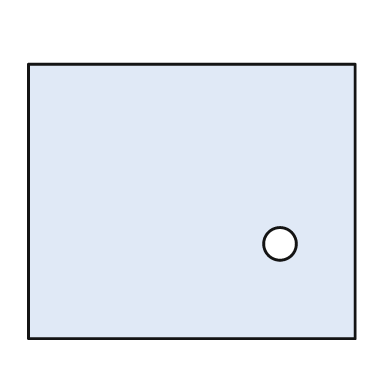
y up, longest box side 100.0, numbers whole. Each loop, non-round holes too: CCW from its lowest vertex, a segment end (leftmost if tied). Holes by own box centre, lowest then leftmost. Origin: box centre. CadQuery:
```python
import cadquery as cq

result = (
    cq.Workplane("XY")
    .moveTo(-50.0, -42.0)
    .lineTo(50.0, -42.0)
    .lineTo(50.0, 42.0)
    .lineTo(-50.0, 42.0)
    .close()
    .moveTo(27.0, -13.0)
    .circle(5.0)
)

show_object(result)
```